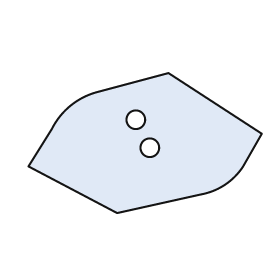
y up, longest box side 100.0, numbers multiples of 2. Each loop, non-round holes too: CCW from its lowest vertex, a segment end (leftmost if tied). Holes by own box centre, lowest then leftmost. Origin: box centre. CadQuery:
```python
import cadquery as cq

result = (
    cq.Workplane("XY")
    .moveTo(-12.0, -30.0)
    .lineTo(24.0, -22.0)
    .threePointArc((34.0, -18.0), (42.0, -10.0))
    .lineTo(50.0, 4.0)
    .lineTo(10.0, 30.0)
    .lineTo(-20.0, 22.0)
    .threePointArc((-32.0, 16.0), (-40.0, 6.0))
    .lineTo(-50.0, -10.0)
    .close()
    .moveTo(2.0, -2.0)
    .circle(4.0)
    .moveTo(-4.0, 10.0)
    .circle(4.0)
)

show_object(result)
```